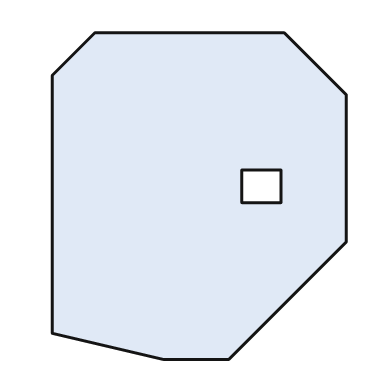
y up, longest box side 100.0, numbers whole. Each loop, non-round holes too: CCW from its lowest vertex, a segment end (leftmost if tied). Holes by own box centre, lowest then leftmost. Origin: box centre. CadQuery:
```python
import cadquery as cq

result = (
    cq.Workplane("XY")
    .moveTo(-11.0, -50.0)
    .lineTo(9.0, -50.0)
    .lineTo(45.0, -14.0)
    .lineTo(45.0, 31.0)
    .lineTo(26.0, 50.0)
    .lineTo(-32.0, 50.0)
    .lineTo(-45.0, 37.0)
    .lineTo(-45.0, -42.0)
    .close()
    .moveTo(13.0, -2.0)
    .lineTo(25.0, -2.0)
    .lineTo(25.0, 8.0)
    .lineTo(13.0, 8.0)
    .close()
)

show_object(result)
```